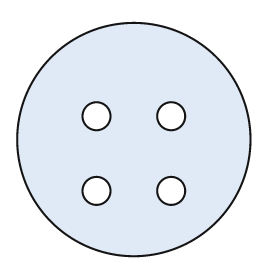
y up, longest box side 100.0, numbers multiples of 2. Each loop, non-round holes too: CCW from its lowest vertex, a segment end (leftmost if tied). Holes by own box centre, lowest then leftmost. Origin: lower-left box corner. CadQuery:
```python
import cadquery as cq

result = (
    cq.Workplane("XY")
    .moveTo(50.0, 50.0)
    .circle(50.0)
    .moveTo(34.0, 28.0)
    .circle(6.0)
    .moveTo(66.0, 28.0)
    .circle(6.0)
    .moveTo(34.0, 60.0)
    .circle(6.0)
    .moveTo(66.0, 60.0)
    .circle(6.0)
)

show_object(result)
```